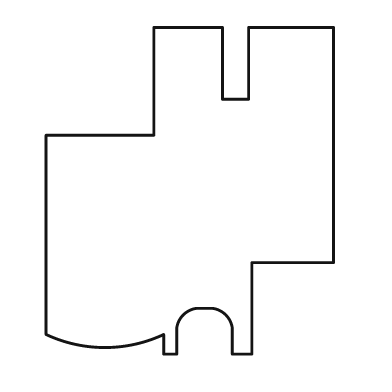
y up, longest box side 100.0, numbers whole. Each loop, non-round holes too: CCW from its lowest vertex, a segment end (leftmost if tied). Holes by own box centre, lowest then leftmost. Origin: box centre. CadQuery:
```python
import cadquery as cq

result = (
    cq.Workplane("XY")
    .moveTo(-8.0, -50.0)
    .lineTo(-4.0, -50.0)
    .lineTo(-4.0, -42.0)
    .threePointArc((-2.0, -38.0), (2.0, -36.0))
    .lineTo(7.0, -36.0)
    .threePointArc((11.0, -38.0), (13.0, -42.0))
    .lineTo(13.0, -50.0)
    .lineTo(19.0, -50.0)
    .lineTo(19.0, -22.0)
    .lineTo(44.0, -22.0)
    .lineTo(44.0, 50.0)
    .lineTo(18.0, 50.0)
    .lineTo(18.0, 28.0)
    .lineTo(10.0, 28.0)
    .lineTo(10.0, 50.0)
    .lineTo(-11.0, 50.0)
    .lineTo(-11.0, 17.0)
    .lineTo(-44.0, 17.0)
    .lineTo(-44.0, -44.0)
    .threePointArc((-26.0, -48.0), (-8.0, -44.0))
    .close()
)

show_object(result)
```